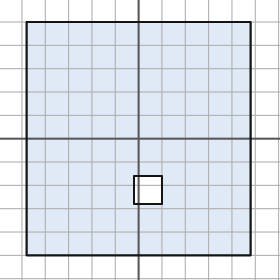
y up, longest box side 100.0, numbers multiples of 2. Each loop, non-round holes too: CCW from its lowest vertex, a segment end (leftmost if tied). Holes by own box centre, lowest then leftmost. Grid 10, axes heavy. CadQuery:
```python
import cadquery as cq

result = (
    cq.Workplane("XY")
    .moveTo(-48.0, -50.0)
    .lineTo(48.0, -50.0)
    .lineTo(48.0, 50.0)
    .lineTo(-48.0, 50.0)
    .close()
    .moveTo(-2.0, -28.0)
    .lineTo(10.0, -28.0)
    .lineTo(10.0, -16.0)
    .lineTo(-2.0, -16.0)
    .close()
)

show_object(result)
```